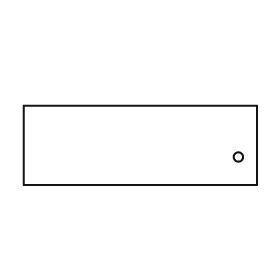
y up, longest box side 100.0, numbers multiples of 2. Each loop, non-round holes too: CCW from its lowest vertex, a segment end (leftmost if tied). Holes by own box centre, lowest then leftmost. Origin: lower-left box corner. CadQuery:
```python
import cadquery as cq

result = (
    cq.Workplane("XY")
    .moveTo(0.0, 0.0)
    .lineTo(100.0, 0.0)
    .lineTo(100.0, 34.0)
    .lineTo(0.0, 34.0)
    .close()
    .moveTo(92.0, 12.0)
    .circle(2.0)
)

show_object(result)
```